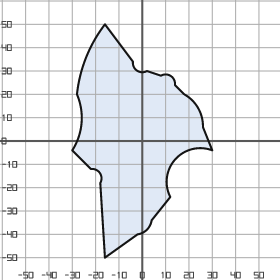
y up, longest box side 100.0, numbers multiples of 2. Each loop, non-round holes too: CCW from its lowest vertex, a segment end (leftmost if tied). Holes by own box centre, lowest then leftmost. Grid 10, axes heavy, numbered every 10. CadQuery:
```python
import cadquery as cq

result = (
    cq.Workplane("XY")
    .moveTo(-16.0, -50.0)
    .lineTo(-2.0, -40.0)
    .threePointArc((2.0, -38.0), (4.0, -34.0))
    .lineTo(12.0, -24.0)
    .threePointArc((14.0, -8.0), (30.0, -4.0))
    .lineTo(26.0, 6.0)
    .threePointArc((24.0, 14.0), (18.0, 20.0))
    .lineTo(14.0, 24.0)
    .threePointArc((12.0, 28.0), (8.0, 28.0))
    .lineTo(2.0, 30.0)
    .threePointArc((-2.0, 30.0), (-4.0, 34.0))
    .lineTo(-16.0, 50.0)
    .threePointArc((-24.0, 36.0), (-28.0, 20.0))
    .threePointArc((-26.0, 8.0), (-30.0, -4.0))
    .lineTo(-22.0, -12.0)
    .threePointArc((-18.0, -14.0), (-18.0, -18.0))
    .close()
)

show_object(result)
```